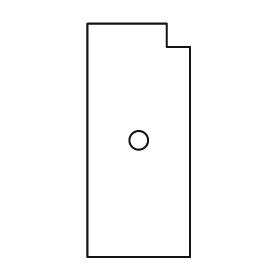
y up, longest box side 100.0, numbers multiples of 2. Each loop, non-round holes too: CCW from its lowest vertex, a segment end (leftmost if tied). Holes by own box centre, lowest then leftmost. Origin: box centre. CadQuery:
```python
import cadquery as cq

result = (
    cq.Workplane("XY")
    .moveTo(-22.0, -50.0)
    .lineTo(22.0, -50.0)
    .lineTo(22.0, 40.0)
    .lineTo(12.0, 40.0)
    .lineTo(12.0, 50.0)
    .lineTo(-22.0, 50.0)
    .close()
    .moveTo(0.0, 0.0)
    .circle(4.0)
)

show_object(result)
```